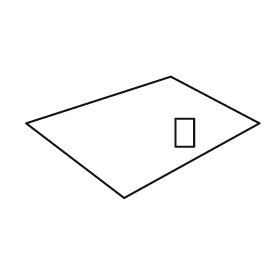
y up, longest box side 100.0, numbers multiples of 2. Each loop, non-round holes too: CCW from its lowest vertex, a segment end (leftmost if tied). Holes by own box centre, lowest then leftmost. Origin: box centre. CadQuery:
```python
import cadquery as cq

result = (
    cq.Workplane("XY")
    .moveTo(-8.0, -26.0)
    .lineTo(50.0, 6.0)
    .lineTo(12.0, 26.0)
    .lineTo(-50.0, 6.0)
    .close()
    .moveTo(14.0, -4.0)
    .lineTo(22.0, -4.0)
    .lineTo(22.0, 8.0)
    .lineTo(14.0, 8.0)
    .close()
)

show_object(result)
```